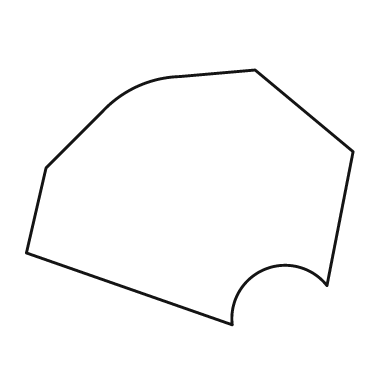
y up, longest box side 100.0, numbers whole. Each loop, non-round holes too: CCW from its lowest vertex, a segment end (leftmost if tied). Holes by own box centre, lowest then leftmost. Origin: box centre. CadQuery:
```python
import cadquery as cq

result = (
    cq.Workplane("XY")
    .moveTo(13.0, -39.0)
    .threePointArc((23.0, -22.0), (42.0, -27.0))
    .lineTo(50.0, 14.0)
    .lineTo(20.0, 39.0)
    .lineTo(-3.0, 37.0)
    .threePointArc((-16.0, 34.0), (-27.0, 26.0))
    .lineTo(-44.0, 9.0)
    .lineTo(-50.0, -17.0)
    .close()
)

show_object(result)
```